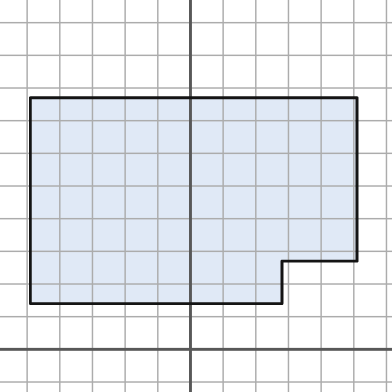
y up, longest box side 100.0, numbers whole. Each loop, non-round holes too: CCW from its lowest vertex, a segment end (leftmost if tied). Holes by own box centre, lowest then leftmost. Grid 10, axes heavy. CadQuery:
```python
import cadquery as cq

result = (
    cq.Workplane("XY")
    .moveTo(-49.0, 14.0)
    .lineTo(28.0, 14.0)
    .lineTo(28.0, 27.0)
    .lineTo(51.0, 27.0)
    .lineTo(51.0, 77.0)
    .lineTo(-49.0, 77.0)
    .close()
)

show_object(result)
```